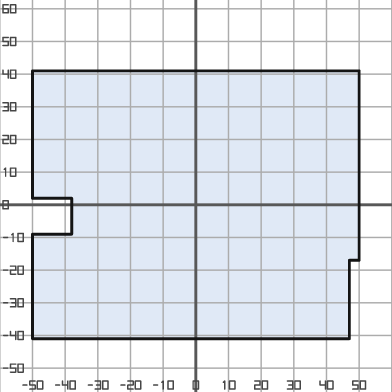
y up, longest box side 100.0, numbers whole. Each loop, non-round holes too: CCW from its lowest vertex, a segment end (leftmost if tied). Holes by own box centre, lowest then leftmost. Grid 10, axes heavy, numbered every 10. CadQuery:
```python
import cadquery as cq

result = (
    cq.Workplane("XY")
    .moveTo(-50.0, -41.0)
    .lineTo(47.0, -41.0)
    .lineTo(47.0, -17.0)
    .lineTo(50.0, -17.0)
    .lineTo(50.0, 41.0)
    .lineTo(-50.0, 41.0)
    .lineTo(-50.0, 2.0)
    .lineTo(-38.0, 2.0)
    .lineTo(-38.0, -9.0)
    .lineTo(-50.0, -9.0)
    .close()
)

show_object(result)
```